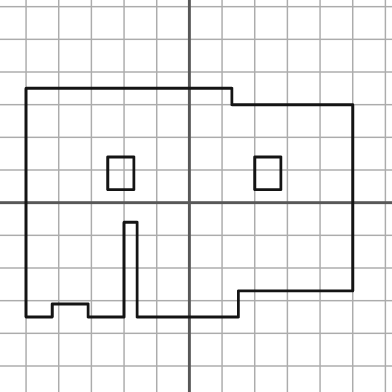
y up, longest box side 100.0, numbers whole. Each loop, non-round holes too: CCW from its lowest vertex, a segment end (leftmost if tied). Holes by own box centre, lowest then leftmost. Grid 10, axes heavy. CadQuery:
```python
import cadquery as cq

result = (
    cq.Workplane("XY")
    .moveTo(-50.0, -35.0)
    .lineTo(-42.0, -35.0)
    .lineTo(-42.0, -31.0)
    .lineTo(-31.0, -31.0)
    .lineTo(-31.0, -35.0)
    .lineTo(-20.0, -35.0)
    .lineTo(-20.0, -6.0)
    .lineTo(-16.0, -6.0)
    .lineTo(-16.0, -35.0)
    .lineTo(15.0, -35.0)
    .lineTo(15.0, -27.0)
    .lineTo(50.0, -27.0)
    .lineTo(50.0, 30.0)
    .lineTo(13.0, 30.0)
    .lineTo(13.0, 35.0)
    .lineTo(-50.0, 35.0)
    .close()
    .moveTo(-25.0, 4.0)
    .lineTo(-17.0, 4.0)
    .lineTo(-17.0, 14.0)
    .lineTo(-25.0, 14.0)
    .close()
    .moveTo(20.0, 4.0)
    .lineTo(28.0, 4.0)
    .lineTo(28.0, 14.0)
    .lineTo(20.0, 14.0)
    .close()
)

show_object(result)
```